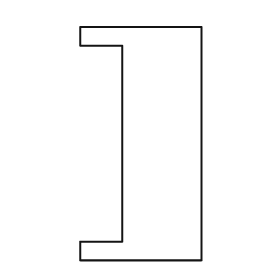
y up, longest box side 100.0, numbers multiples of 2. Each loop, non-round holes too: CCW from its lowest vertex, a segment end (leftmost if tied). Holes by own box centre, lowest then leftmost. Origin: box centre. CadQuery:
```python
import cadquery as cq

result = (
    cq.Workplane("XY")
    .moveTo(-26.0, -50.0)
    .lineTo(26.0, -50.0)
    .lineTo(26.0, 50.0)
    .lineTo(-26.0, 50.0)
    .lineTo(-26.0, 42.0)
    .lineTo(-8.0, 42.0)
    .lineTo(-8.0, -42.0)
    .lineTo(-26.0, -42.0)
    .close()
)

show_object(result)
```